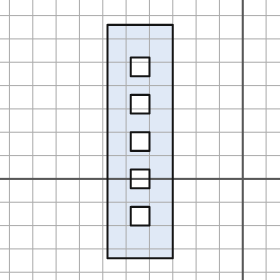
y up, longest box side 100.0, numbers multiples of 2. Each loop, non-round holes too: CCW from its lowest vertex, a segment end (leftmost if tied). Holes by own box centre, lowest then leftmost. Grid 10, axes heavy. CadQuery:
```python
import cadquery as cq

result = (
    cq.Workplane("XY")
    .moveTo(-58.0, -34.0)
    .lineTo(-30.0, -34.0)
    .lineTo(-30.0, 66.0)
    .lineTo(-58.0, 66.0)
    .close()
    .moveTo(-48.0, -20.0)
    .lineTo(-40.0, -20.0)
    .lineTo(-40.0, -12.0)
    .lineTo(-48.0, -12.0)
    .close()
    .moveTo(-48.0, -4.0)
    .lineTo(-40.0, -4.0)
    .lineTo(-40.0, 4.0)
    .lineTo(-48.0, 4.0)
    .close()
    .moveTo(-48.0, 12.0)
    .lineTo(-40.0, 12.0)
    .lineTo(-40.0, 20.0)
    .lineTo(-48.0, 20.0)
    .close()
    .moveTo(-48.0, 28.0)
    .lineTo(-40.0, 28.0)
    .lineTo(-40.0, 36.0)
    .lineTo(-48.0, 36.0)
    .close()
    .moveTo(-48.0, 44.0)
    .lineTo(-40.0, 44.0)
    .lineTo(-40.0, 52.0)
    .lineTo(-48.0, 52.0)
    .close()
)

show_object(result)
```